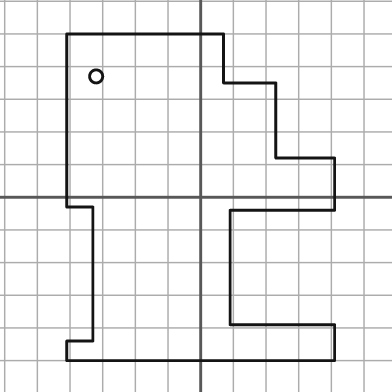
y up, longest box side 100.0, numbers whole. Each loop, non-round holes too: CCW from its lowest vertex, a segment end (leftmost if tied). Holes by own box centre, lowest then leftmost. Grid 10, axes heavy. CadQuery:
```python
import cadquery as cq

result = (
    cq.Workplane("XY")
    .moveTo(-41.0, -50.0)
    .lineTo(41.0, -50.0)
    .lineTo(41.0, -39.0)
    .lineTo(9.0, -39.0)
    .lineTo(9.0, -4.0)
    .lineTo(41.0, -4.0)
    .lineTo(41.0, 12.0)
    .lineTo(23.0, 12.0)
    .lineTo(23.0, 35.0)
    .lineTo(7.0, 35.0)
    .lineTo(7.0, 50.0)
    .lineTo(-41.0, 50.0)
    .lineTo(-41.0, -3.0)
    .lineTo(-33.0, -3.0)
    .lineTo(-33.0, -44.0)
    .lineTo(-41.0, -44.0)
    .close()
    .moveTo(-32.0, 37.0)
    .circle(2.0)
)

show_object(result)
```